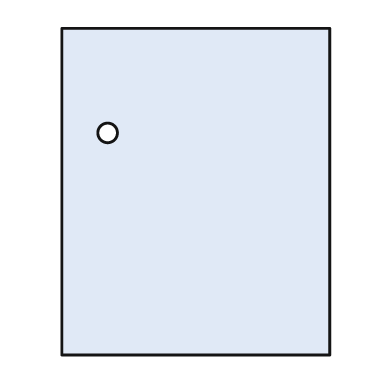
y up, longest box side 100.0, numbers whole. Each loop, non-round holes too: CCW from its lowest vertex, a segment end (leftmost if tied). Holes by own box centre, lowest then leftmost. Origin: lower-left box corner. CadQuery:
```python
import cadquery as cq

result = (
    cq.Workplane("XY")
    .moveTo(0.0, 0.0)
    .lineTo(82.0, 0.0)
    .lineTo(82.0, 100.0)
    .lineTo(0.0, 100.0)
    .close()
    .moveTo(14.0, 68.0)
    .circle(3.0)
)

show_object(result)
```